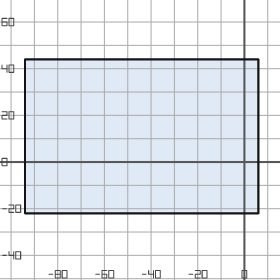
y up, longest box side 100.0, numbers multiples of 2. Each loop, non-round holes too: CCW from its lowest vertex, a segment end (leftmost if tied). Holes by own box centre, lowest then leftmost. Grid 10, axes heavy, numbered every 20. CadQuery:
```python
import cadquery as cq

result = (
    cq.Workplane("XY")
    .moveTo(-94.0, -22.0)
    .lineTo(6.0, -22.0)
    .lineTo(6.0, 44.0)
    .lineTo(-94.0, 44.0)
    .close()
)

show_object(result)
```